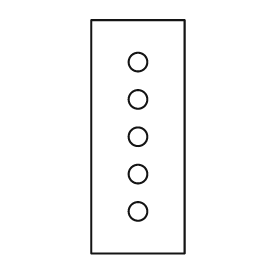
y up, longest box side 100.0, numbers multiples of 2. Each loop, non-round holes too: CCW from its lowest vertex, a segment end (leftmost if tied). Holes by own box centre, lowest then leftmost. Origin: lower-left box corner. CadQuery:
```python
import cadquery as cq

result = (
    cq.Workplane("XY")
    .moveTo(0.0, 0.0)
    .lineTo(40.0, 0.0)
    .lineTo(40.0, 100.0)
    .lineTo(0.0, 100.0)
    .close()
    .moveTo(20.0, 18.0)
    .circle(4.0)
    .moveTo(20.0, 34.0)
    .circle(4.0)
    .moveTo(20.0, 50.0)
    .circle(4.0)
    .moveTo(20.0, 66.0)
    .circle(4.0)
    .moveTo(20.0, 82.0)
    .circle(4.0)
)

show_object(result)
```